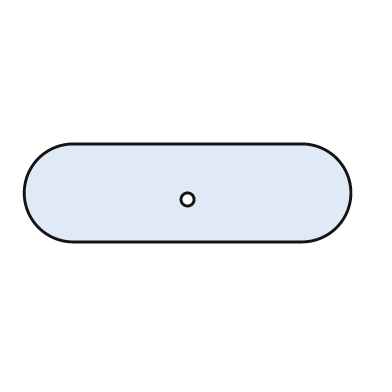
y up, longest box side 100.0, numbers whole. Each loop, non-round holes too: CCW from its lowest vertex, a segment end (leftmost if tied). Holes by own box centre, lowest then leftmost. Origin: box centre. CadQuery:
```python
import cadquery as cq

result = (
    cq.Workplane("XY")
    .moveTo(-35.0, -15.0)
    .lineTo(35.0, -15.0)
    .threePointArc((50.0, 0.0), (35.0, 15.0))
    .lineTo(-35.0, 15.0)
    .threePointArc((-50.0, 0.0), (-35.0, -15.0))
    .close()
    .moveTo(0.0, -2.0)
    .circle(2.0)
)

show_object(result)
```